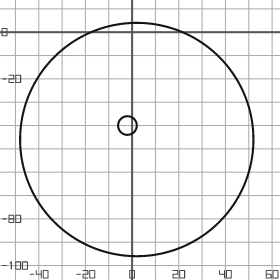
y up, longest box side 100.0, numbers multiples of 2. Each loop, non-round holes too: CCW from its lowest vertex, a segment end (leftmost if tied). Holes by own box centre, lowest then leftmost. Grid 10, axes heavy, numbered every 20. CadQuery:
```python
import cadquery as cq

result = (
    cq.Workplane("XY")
    .moveTo(2.0, -46.0)
    .circle(50.0)
    .moveTo(-2.0, -40.0)
    .circle(4.0)
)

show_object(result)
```